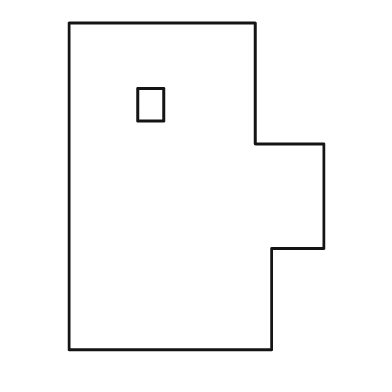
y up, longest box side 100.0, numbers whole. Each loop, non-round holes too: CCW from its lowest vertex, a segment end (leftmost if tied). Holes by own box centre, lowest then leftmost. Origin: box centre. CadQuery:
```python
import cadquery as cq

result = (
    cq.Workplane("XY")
    .moveTo(-39.0, -50.0)
    .lineTo(23.0, -50.0)
    .lineTo(23.0, -19.0)
    .lineTo(39.0, -19.0)
    .lineTo(39.0, 13.0)
    .lineTo(18.0, 13.0)
    .lineTo(18.0, 50.0)
    .lineTo(-39.0, 50.0)
    .close()
    .moveTo(-18.0, 20.0)
    .lineTo(-10.0, 20.0)
    .lineTo(-10.0, 30.0)
    .lineTo(-18.0, 30.0)
    .close()
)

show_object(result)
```